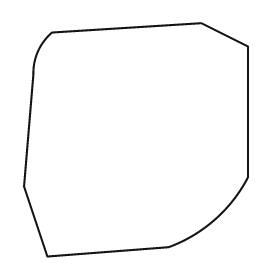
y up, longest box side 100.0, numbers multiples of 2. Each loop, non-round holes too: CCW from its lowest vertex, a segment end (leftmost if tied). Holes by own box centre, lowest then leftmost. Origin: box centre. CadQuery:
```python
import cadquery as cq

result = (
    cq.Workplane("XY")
    .moveTo(-38.0, -50.0)
    .lineTo(14.0, -46.0)
    .threePointArc((34.0, -34.0), (48.0, -16.0))
    .lineTo(48.0, 40.0)
    .lineTo(28.0, 50.0)
    .lineTo(-36.0, 46.0)
    .threePointArc((-42.0, 38.0), (-44.0, 28.0))
    .lineTo(-48.0, -20.0)
    .close()
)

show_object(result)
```